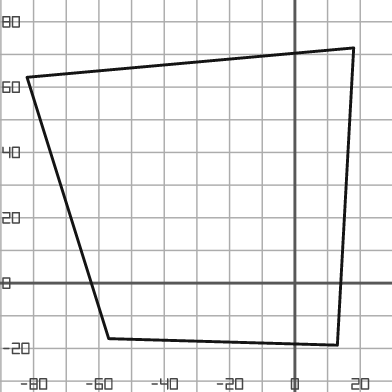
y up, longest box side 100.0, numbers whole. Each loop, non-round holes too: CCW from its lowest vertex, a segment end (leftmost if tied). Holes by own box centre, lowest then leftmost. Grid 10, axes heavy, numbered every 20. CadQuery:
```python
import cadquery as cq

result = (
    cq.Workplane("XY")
    .moveTo(13.0, -19.0)
    .lineTo(18.0, 72.0)
    .lineTo(-82.0, 63.0)
    .lineTo(-57.0, -17.0)
    .close()
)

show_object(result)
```